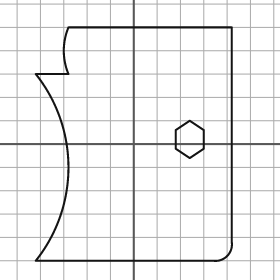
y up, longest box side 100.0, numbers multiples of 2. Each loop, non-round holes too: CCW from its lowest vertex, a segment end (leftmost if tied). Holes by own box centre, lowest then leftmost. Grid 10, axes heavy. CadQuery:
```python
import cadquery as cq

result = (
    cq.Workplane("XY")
    .moveTo(-42.0, -50.0)
    .lineTo(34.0, -50.0)
    .threePointArc((40.0, -48.0), (42.0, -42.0))
    .lineTo(42.0, 50.0)
    .lineTo(-28.0, 50.0)
    .threePointArc((-30.0, 40.0), (-28.0, 30.0))
    .lineTo(-42.0, 30.0)
    .threePointArc((-28.0, -10.0), (-42.0, -50.0))
    .close()
    .moveTo(24.0, -6.0)
    .lineTo(30.0, -2.0)
    .lineTo(30.0, 6.0)
    .lineTo(24.0, 10.0)
    .lineTo(18.0, 6.0)
    .lineTo(18.0, -2.0)
    .close()
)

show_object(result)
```